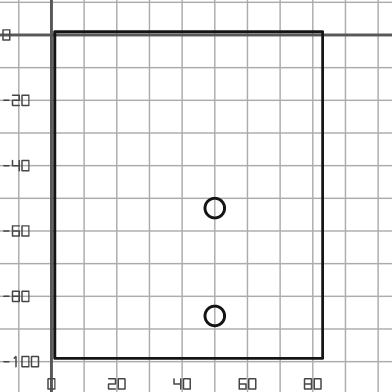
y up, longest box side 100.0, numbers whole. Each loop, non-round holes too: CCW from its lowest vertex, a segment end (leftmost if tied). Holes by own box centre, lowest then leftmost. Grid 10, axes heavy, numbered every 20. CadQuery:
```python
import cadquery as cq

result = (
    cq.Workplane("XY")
    .moveTo(1.0, -99.0)
    .lineTo(83.0, -99.0)
    .lineTo(83.0, 1.0)
    .lineTo(1.0, 1.0)
    .close()
    .moveTo(50.0, -86.0)
    .circle(3.0)
    .moveTo(50.0, -53.0)
    .circle(3.0)
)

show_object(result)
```